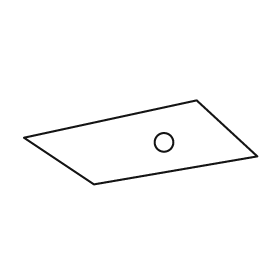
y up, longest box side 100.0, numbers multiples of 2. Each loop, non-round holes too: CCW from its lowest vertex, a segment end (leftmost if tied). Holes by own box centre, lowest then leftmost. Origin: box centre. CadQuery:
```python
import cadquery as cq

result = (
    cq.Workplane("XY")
    .moveTo(-20.0, -18.0)
    .lineTo(50.0, -6.0)
    .lineTo(24.0, 18.0)
    .lineTo(-50.0, 2.0)
    .close()
    .moveTo(10.0, 0.0)
    .circle(4.0)
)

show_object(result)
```